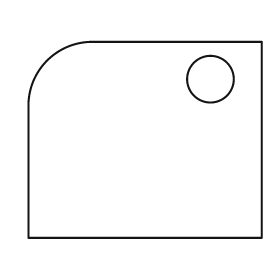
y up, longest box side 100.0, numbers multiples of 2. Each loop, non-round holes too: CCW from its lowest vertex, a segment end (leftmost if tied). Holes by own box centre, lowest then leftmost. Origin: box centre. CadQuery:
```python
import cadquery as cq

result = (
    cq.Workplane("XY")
    .moveTo(-50.0, -42.0)
    .lineTo(50.0, -42.0)
    .lineTo(50.0, 42.0)
    .lineTo(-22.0, 42.0)
    .threePointArc((-42.0, 34.0), (-50.0, 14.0))
    .close()
    .moveTo(28.0, 26.0)
    .circle(10.0)
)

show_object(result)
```